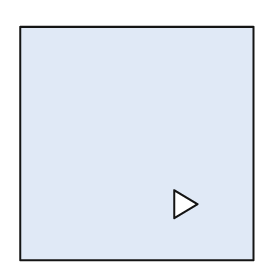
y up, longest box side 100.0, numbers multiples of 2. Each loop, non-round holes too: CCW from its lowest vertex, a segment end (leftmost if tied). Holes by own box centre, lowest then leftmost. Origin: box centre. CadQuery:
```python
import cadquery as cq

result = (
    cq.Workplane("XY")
    .moveTo(-50.0, -50.0)
    .lineTo(50.0, -50.0)
    .lineTo(50.0, 50.0)
    .lineTo(-50.0, 50.0)
    .close()
    .moveTo(16.0, -32.0)
    .lineTo(26.0, -26.0)
    .lineTo(16.0, -20.0)
    .close()
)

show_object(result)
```